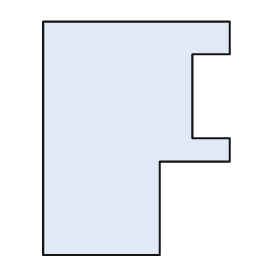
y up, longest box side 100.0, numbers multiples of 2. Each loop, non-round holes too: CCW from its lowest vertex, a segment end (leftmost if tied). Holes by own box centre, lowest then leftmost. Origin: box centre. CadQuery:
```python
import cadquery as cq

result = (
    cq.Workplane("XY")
    .moveTo(-40.0, -50.0)
    .lineTo(10.0, -50.0)
    .lineTo(10.0, -10.0)
    .lineTo(40.0, -10.0)
    .lineTo(40.0, 0.0)
    .lineTo(24.0, 0.0)
    .lineTo(24.0, 36.0)
    .lineTo(40.0, 36.0)
    .lineTo(40.0, 50.0)
    .lineTo(-40.0, 50.0)
    .close()
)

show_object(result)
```